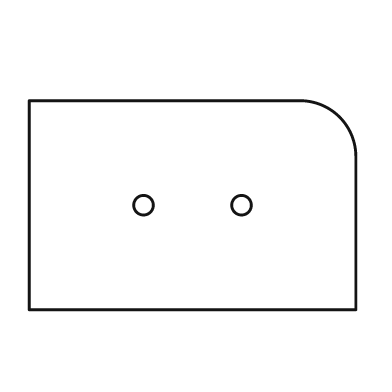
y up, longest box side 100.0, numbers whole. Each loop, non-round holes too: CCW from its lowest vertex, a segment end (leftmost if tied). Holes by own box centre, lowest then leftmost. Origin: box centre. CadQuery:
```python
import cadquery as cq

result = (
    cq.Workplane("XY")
    .moveTo(-50.0, -32.0)
    .lineTo(50.0, -32.0)
    .lineTo(50.0, 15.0)
    .threePointArc((45.0, 27.0), (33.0, 32.0))
    .lineTo(-50.0, 32.0)
    .close()
    .moveTo(-15.0, 0.0)
    .circle(3.0)
    .moveTo(15.0, 0.0)
    .circle(3.0)
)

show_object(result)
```